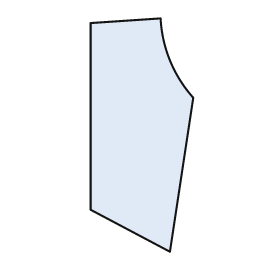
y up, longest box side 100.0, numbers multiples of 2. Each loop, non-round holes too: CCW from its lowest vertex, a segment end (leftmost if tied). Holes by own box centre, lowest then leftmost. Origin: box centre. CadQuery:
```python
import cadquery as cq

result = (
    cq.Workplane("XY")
    .moveTo(12.0, -50.0)
    .lineTo(22.0, 16.0)
    .threePointArc((12.0, 32.0), (8.0, 50.0))
    .lineTo(-22.0, 48.0)
    .lineTo(-22.0, -32.0)
    .close()
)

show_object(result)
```